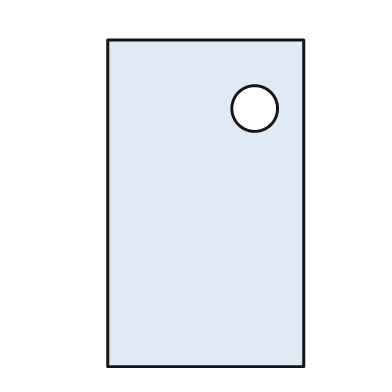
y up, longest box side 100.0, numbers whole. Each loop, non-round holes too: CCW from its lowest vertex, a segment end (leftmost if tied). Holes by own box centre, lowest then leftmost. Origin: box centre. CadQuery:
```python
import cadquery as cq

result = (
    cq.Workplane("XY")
    .moveTo(-30.0, -50.0)
    .lineTo(30.0, -50.0)
    .lineTo(30.0, 50.0)
    .lineTo(-30.0, 50.0)
    .close()
    .moveTo(15.0, 29.0)
    .circle(7.0)
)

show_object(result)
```